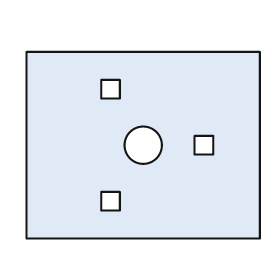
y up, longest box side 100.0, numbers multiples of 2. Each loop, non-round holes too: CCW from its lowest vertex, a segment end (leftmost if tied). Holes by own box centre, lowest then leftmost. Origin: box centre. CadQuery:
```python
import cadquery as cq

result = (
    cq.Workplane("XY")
    .moveTo(-50.0, -40.0)
    .lineTo(50.0, -40.0)
    .lineTo(50.0, 40.0)
    .lineTo(-50.0, 40.0)
    .close()
    .moveTo(-18.0, -28.0)
    .lineTo(-10.0, -28.0)
    .lineTo(-10.0, -20.0)
    .lineTo(-18.0, -20.0)
    .close()
    .moveTo(0.0, 0.0)
    .circle(8.0)
    .moveTo(22.0, -4.0)
    .lineTo(30.0, -4.0)
    .lineTo(30.0, 4.0)
    .lineTo(22.0, 4.0)
    .close()
    .moveTo(-18.0, 20.0)
    .lineTo(-10.0, 20.0)
    .lineTo(-10.0, 28.0)
    .lineTo(-18.0, 28.0)
    .close()
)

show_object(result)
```